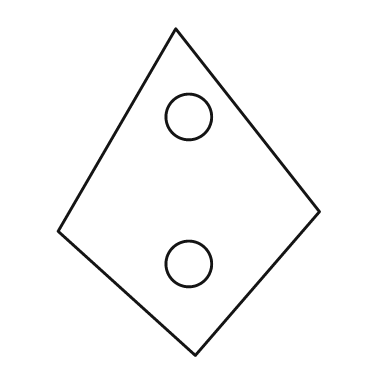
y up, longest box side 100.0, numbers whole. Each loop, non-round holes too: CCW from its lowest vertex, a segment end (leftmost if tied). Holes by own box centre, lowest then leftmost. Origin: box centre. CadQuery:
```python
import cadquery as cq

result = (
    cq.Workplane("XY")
    .moveTo(2.0, -50.0)
    .lineTo(40.0, -6.0)
    .lineTo(-4.0, 50.0)
    .lineTo(-40.0, -12.0)
    .close()
    .moveTo(0.0, -22.0)
    .circle(7.0)
    .moveTo(0.0, 23.0)
    .circle(7.0)
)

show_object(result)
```